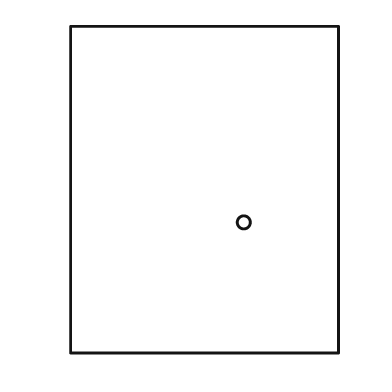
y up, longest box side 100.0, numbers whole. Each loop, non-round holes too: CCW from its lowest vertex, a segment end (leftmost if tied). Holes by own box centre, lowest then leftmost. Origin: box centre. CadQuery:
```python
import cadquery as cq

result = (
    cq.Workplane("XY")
    .moveTo(-41.0, -50.0)
    .lineTo(41.0, -50.0)
    .lineTo(41.0, 50.0)
    .lineTo(-41.0, 50.0)
    .close()
    .moveTo(12.0, -10.0)
    .circle(2.0)
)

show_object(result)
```